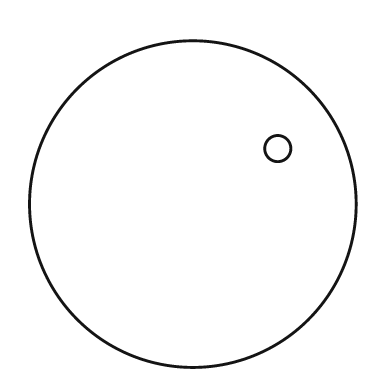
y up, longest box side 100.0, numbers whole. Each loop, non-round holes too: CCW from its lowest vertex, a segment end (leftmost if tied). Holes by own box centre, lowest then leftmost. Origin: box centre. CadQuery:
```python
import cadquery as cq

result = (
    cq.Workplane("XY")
    .moveTo(0.0, 0.0)
    .circle(50.0)
    .moveTo(26.0, 17.0)
    .circle(4.0)
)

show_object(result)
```